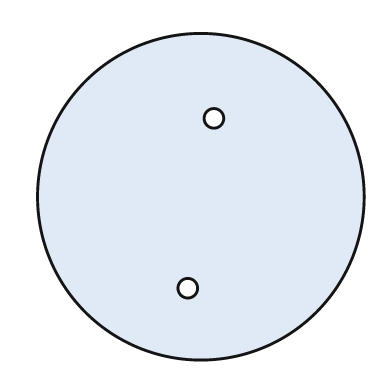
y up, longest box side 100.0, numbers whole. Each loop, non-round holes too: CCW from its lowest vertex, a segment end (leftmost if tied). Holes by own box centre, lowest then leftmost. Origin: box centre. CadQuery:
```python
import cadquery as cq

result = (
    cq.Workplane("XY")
    .moveTo(0.0, 0.0)
    .circle(50.0)
    .moveTo(-4.0, -28.0)
    .circle(3.0)
    .moveTo(4.0, 24.0)
    .circle(3.0)
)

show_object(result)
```